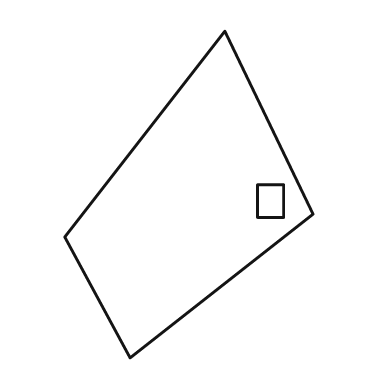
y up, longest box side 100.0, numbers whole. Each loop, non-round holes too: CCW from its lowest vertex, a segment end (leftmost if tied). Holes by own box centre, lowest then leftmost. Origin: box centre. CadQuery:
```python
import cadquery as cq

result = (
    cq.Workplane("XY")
    .moveTo(-18.0, -50.0)
    .lineTo(38.0, -6.0)
    .lineTo(11.0, 50.0)
    .lineTo(-38.0, -13.0)
    .close()
    .moveTo(21.0, -7.0)
    .lineTo(29.0, -7.0)
    .lineTo(29.0, 3.0)
    .lineTo(21.0, 3.0)
    .close()
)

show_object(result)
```